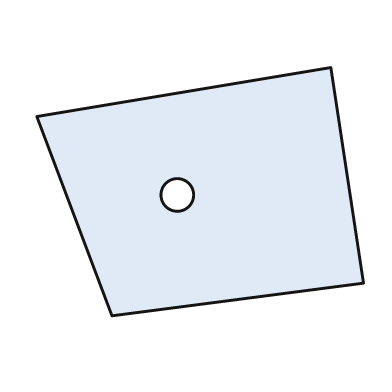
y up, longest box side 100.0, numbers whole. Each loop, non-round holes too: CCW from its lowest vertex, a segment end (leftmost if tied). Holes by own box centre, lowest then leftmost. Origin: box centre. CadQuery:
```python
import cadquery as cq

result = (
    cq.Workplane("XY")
    .moveTo(-27.0, -38.0)
    .lineTo(50.0, -28.0)
    .lineTo(40.0, 38.0)
    .lineTo(-50.0, 23.0)
    .close()
    .moveTo(-7.0, -1.0)
    .circle(5.0)
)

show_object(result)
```